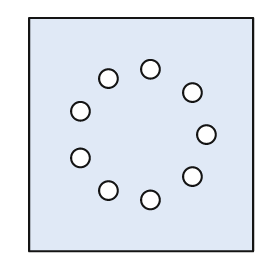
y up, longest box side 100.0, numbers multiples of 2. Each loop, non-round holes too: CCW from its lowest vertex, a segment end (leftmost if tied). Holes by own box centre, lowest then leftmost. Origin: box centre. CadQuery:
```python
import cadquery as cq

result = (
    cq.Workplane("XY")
    .moveTo(-48.0, -50.0)
    .lineTo(48.0, -50.0)
    .lineTo(48.0, 50.0)
    .lineTo(-48.0, 50.0)
    .close()
    .moveTo(4.0, -28.0)
    .circle(4.0)
    .moveTo(-14.0, -24.0)
    .circle(4.0)
    .moveTo(22.0, -18.0)
    .circle(4.0)
    .moveTo(-26.0, -10.0)
    .circle(4.0)
    .moveTo(28.0, 0.0)
    .circle(4.0)
    .moveTo(-26.0, 10.0)
    .circle(4.0)
    .moveTo(22.0, 18.0)
    .circle(4.0)
    .moveTo(-14.0, 24.0)
    .circle(4.0)
    .moveTo(4.0, 28.0)
    .circle(4.0)
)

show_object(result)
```